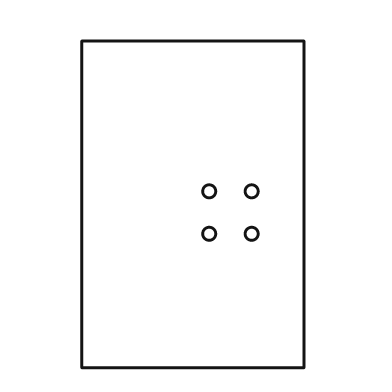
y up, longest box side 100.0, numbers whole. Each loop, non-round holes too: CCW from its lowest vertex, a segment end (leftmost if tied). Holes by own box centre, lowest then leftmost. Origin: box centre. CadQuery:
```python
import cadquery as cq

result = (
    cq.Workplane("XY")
    .moveTo(-34.0, -50.0)
    .lineTo(34.0, -50.0)
    .lineTo(34.0, 50.0)
    .lineTo(-34.0, 50.0)
    .close()
    .moveTo(5.0, -9.0)
    .circle(2.0)
    .moveTo(18.0, -9.0)
    .circle(2.0)
    .moveTo(5.0, 4.0)
    .circle(2.0)
    .moveTo(18.0, 4.0)
    .circle(2.0)
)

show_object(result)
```